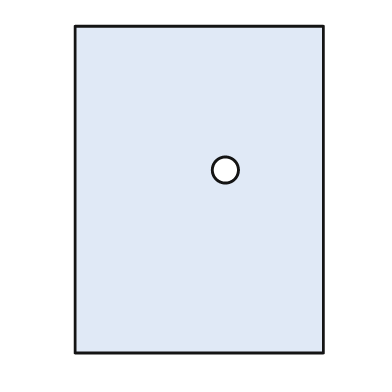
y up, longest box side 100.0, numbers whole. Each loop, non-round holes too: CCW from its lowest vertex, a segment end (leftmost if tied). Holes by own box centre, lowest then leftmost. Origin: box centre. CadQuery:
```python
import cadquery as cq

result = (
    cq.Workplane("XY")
    .moveTo(-38.0, -50.0)
    .lineTo(38.0, -50.0)
    .lineTo(38.0, 50.0)
    .lineTo(-38.0, 50.0)
    .close()
    .moveTo(8.0, 6.0)
    .circle(4.0)
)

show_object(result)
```